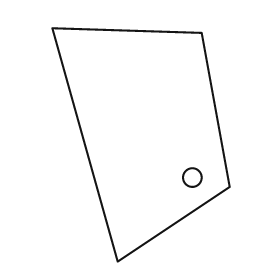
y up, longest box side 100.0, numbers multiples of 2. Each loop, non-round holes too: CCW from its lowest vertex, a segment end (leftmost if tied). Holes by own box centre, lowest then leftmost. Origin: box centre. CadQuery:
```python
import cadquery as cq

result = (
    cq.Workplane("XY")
    .moveTo(-10.0, -50.0)
    .lineTo(38.0, -18.0)
    .lineTo(26.0, 48.0)
    .lineTo(-38.0, 50.0)
    .close()
    .moveTo(22.0, -14.0)
    .circle(4.0)
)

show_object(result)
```